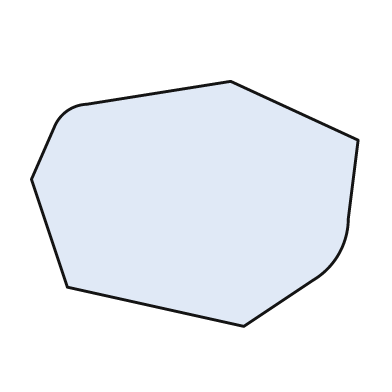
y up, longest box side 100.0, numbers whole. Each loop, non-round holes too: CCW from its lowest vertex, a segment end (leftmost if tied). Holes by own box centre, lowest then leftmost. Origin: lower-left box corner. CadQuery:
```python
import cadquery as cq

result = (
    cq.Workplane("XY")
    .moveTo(65.0, 0.0)
    .lineTo(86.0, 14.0)
    .threePointArc((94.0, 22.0), (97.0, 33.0))
    .lineTo(100.0, 57.0)
    .lineTo(61.0, 75.0)
    .lineTo(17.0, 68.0)
    .threePointArc((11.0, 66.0), (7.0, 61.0))
    .lineTo(0.0, 45.0)
    .lineTo(11.0, 12.0)
    .close()
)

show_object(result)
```